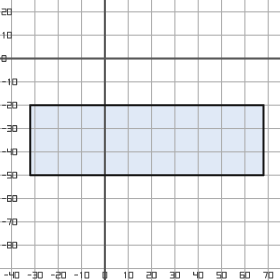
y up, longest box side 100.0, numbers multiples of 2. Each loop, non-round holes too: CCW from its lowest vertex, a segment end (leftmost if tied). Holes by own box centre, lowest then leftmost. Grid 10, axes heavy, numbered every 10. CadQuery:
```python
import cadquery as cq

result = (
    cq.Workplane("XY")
    .moveTo(-32.0, -50.0)
    .lineTo(68.0, -50.0)
    .lineTo(68.0, -20.0)
    .lineTo(-32.0, -20.0)
    .close()
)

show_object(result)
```